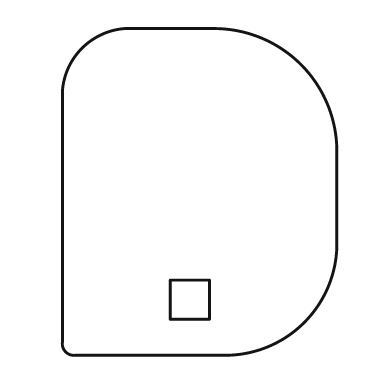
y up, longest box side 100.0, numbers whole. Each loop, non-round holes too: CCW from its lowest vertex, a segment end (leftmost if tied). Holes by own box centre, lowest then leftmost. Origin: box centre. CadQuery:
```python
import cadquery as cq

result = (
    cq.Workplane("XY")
    .moveTo(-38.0, -50.0)
    .lineTo(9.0, -50.0)
    .threePointArc((32.0, -40.0), (42.0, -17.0))
    .lineTo(42.0, 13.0)
    .threePointArc((31.0, 39.0), (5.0, 50.0))
    .lineTo(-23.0, 50.0)
    .threePointArc((-36.0, 44.0), (-42.0, 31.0))
    .lineTo(-42.0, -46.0)
    .threePointArc((-41.0, -49.0), (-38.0, -50.0))
    .close()
    .moveTo(-9.0, -39.0)
    .lineTo(3.0, -39.0)
    .lineTo(3.0, -27.0)
    .lineTo(-9.0, -27.0)
    .close()
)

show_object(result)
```